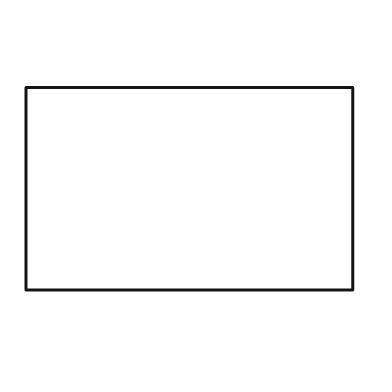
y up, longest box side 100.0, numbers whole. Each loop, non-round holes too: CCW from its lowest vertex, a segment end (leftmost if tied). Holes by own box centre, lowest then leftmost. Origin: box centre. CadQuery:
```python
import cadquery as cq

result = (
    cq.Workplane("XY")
    .moveTo(-50.0, -31.0)
    .lineTo(50.0, -31.0)
    .lineTo(50.0, 31.0)
    .lineTo(-50.0, 31.0)
    .close()
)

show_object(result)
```